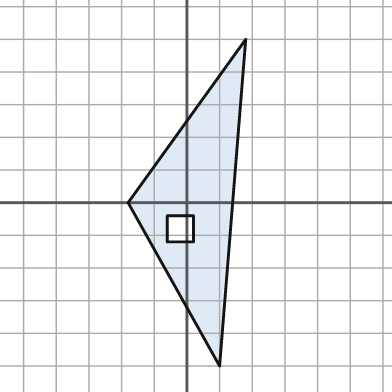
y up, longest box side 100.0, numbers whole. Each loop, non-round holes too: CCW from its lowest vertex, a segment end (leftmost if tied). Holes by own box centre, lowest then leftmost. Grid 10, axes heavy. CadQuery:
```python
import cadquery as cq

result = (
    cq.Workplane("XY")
    .moveTo(10.0, -50.0)
    .lineTo(18.0, 50.0)
    .lineTo(-18.0, 0.0)
    .close()
    .moveTo(-6.0, -12.0)
    .lineTo(2.0, -12.0)
    .lineTo(2.0, -4.0)
    .lineTo(-6.0, -4.0)
    .close()
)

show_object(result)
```